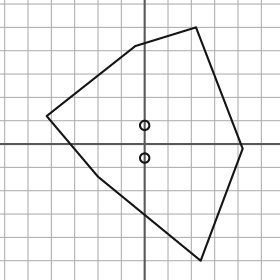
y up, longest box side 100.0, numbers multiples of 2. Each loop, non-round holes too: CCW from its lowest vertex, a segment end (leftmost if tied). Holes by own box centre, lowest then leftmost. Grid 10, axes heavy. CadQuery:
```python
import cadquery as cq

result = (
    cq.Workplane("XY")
    .moveTo(24.0, -50.0)
    .lineTo(42.0, -2.0)
    .lineTo(22.0, 50.0)
    .lineTo(-4.0, 42.0)
    .lineTo(-42.0, 12.0)
    .lineTo(-20.0, -14.0)
    .close()
    .moveTo(0.0, -6.0)
    .circle(2.0)
    .moveTo(0.0, 8.0)
    .circle(2.0)
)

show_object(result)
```